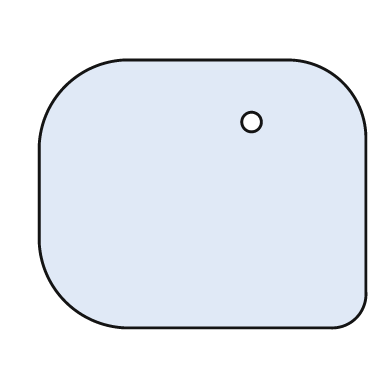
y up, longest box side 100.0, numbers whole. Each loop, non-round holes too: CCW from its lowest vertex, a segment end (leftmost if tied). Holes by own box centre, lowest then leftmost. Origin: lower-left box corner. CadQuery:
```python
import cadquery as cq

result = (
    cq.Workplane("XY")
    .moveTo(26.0, 0.0)
    .lineTo(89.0, 0.0)
    .threePointArc((97.0, 3.0), (100.0, 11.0))
    .lineTo(100.0, 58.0)
    .threePointArc((93.0, 75.0), (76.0, 82.0))
    .lineTo(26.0, 82.0)
    .threePointArc((8.0, 74.0), (0.0, 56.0))
    .lineTo(0.0, 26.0)
    .threePointArc((8.0, 8.0), (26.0, 0.0))
    .close()
    .moveTo(65.0, 63.0)
    .circle(3.0)
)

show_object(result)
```